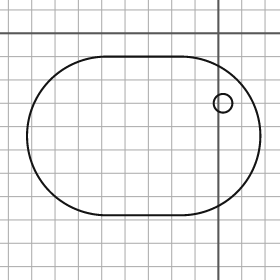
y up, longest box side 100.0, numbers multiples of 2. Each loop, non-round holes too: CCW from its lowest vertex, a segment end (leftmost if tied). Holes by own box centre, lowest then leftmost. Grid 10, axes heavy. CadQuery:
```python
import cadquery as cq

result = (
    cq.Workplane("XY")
    .moveTo(-48.0, -78.0)
    .lineTo(-16.0, -78.0)
    .threePointArc((18.0, -44.0), (-16.0, -10.0))
    .lineTo(-48.0, -10.0)
    .threePointArc((-82.0, -44.0), (-48.0, -78.0))
    .close()
    .moveTo(2.0, -30.0)
    .circle(4.0)
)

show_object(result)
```